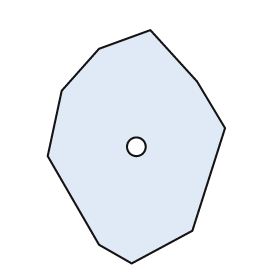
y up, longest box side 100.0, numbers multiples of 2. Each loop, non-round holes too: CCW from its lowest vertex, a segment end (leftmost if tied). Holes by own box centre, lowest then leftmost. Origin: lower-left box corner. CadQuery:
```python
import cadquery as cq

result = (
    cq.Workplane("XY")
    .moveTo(36.0, 0.0)
    .lineTo(62.0, 14.0)
    .lineTo(76.0, 58.0)
    .lineTo(64.0, 78.0)
    .lineTo(44.0, 100.0)
    .lineTo(22.0, 92.0)
    .lineTo(6.0, 74.0)
    .lineTo(0.0, 46.0)
    .lineTo(22.0, 8.0)
    .close()
    .moveTo(38.0, 50.0)
    .circle(4.0)
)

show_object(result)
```